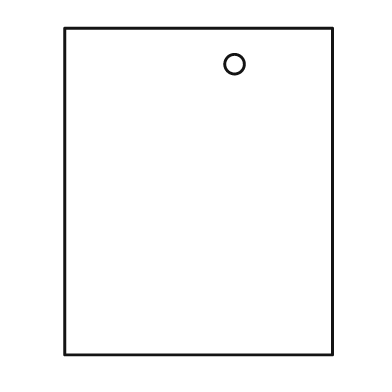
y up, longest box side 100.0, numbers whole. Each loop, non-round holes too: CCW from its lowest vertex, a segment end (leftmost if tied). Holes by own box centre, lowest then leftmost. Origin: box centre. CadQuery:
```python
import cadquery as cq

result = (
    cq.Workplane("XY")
    .moveTo(-41.0, -50.0)
    .lineTo(41.0, -50.0)
    .lineTo(41.0, 50.0)
    .lineTo(-41.0, 50.0)
    .close()
    .moveTo(11.0, 39.0)
    .circle(3.0)
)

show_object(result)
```